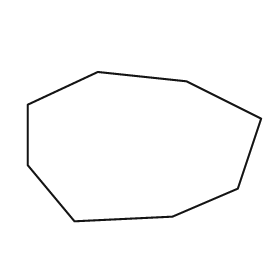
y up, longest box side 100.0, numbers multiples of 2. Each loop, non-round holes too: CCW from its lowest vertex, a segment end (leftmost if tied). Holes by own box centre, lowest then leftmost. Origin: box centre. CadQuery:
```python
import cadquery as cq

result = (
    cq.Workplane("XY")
    .moveTo(-30.0, -32.0)
    .lineTo(12.0, -30.0)
    .lineTo(40.0, -18.0)
    .lineTo(50.0, 12.0)
    .lineTo(18.0, 28.0)
    .lineTo(-20.0, 32.0)
    .lineTo(-50.0, 18.0)
    .lineTo(-50.0, -8.0)
    .close()
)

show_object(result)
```